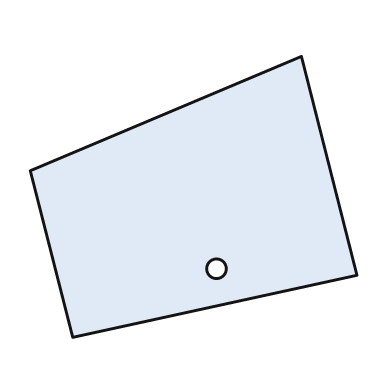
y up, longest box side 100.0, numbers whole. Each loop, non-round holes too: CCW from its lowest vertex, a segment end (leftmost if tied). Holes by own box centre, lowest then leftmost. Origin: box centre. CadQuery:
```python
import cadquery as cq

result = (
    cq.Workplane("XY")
    .moveTo(-37.0, -43.0)
    .lineTo(50.0, -24.0)
    .lineTo(33.0, 43.0)
    .lineTo(-50.0, 8.0)
    .close()
    .moveTo(7.0, -22.0)
    .circle(3.0)
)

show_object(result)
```